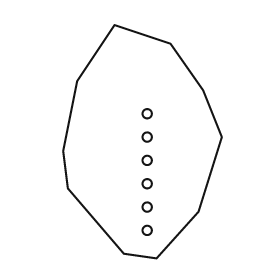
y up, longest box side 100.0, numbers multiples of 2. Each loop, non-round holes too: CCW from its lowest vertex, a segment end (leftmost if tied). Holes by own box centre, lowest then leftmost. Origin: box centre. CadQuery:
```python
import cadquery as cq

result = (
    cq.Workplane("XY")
    .moveTo(6.0, -50.0)
    .lineTo(24.0, -30.0)
    .lineTo(34.0, 2.0)
    .lineTo(26.0, 22.0)
    .lineTo(12.0, 42.0)
    .lineTo(-12.0, 50.0)
    .lineTo(-28.0, 26.0)
    .lineTo(-34.0, -4.0)
    .lineTo(-32.0, -20.0)
    .lineTo(-8.0, -48.0)
    .close()
    .moveTo(2.0, -38.0)
    .circle(2.0)
    .moveTo(2.0, -28.0)
    .circle(2.0)
    .moveTo(2.0, -18.0)
    .circle(2.0)
    .moveTo(2.0, -8.0)
    .circle(2.0)
    .moveTo(2.0, 2.0)
    .circle(2.0)
    .moveTo(2.0, 12.0)
    .circle(2.0)
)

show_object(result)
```